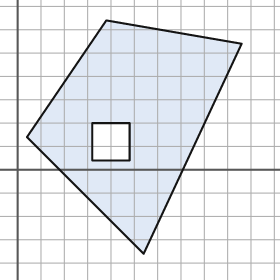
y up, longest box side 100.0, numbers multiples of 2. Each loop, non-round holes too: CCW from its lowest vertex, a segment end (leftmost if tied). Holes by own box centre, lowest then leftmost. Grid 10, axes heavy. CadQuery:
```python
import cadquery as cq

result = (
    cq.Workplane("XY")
    .moveTo(54.0, -36.0)
    .lineTo(96.0, 54.0)
    .lineTo(38.0, 64.0)
    .lineTo(4.0, 14.0)
    .close()
    .moveTo(32.0, 4.0)
    .lineTo(48.0, 4.0)
    .lineTo(48.0, 20.0)
    .lineTo(32.0, 20.0)
    .close()
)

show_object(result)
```